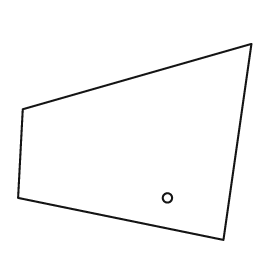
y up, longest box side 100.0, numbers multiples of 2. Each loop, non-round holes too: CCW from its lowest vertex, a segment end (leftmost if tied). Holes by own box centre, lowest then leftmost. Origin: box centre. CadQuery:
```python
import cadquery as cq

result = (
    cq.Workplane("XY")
    .moveTo(38.0, -42.0)
    .lineTo(50.0, 42.0)
    .lineTo(-48.0, 14.0)
    .lineTo(-50.0, -24.0)
    .close()
    .moveTo(14.0, -24.0)
    .circle(2.0)
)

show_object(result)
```